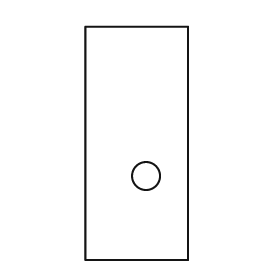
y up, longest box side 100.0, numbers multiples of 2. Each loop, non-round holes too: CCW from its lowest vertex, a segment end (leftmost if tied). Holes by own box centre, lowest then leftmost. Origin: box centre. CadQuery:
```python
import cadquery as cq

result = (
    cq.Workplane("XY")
    .moveTo(-22.0, -50.0)
    .lineTo(22.0, -50.0)
    .lineTo(22.0, 50.0)
    .lineTo(-22.0, 50.0)
    .close()
    .moveTo(4.0, -14.0)
    .circle(6.0)
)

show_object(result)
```